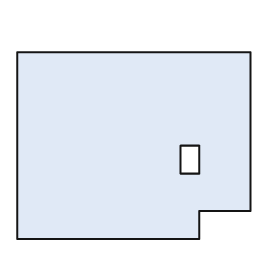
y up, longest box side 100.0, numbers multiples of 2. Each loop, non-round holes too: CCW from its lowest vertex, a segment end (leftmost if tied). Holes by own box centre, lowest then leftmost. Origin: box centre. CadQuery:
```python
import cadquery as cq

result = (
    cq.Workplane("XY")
    .moveTo(-50.0, -40.0)
    .lineTo(28.0, -40.0)
    .lineTo(28.0, -28.0)
    .lineTo(50.0, -28.0)
    .lineTo(50.0, 40.0)
    .lineTo(-50.0, 40.0)
    .close()
    .moveTo(20.0, -12.0)
    .lineTo(28.0, -12.0)
    .lineTo(28.0, 0.0)
    .lineTo(20.0, 0.0)
    .close()
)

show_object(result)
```